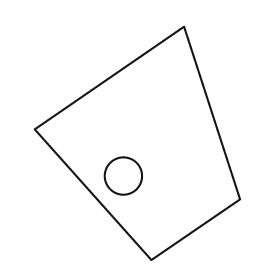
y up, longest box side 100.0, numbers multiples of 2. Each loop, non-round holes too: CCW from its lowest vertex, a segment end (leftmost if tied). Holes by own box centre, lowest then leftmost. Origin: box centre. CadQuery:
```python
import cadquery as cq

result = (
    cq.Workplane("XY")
    .moveTo(6.0, -50.0)
    .lineTo(44.0, -24.0)
    .lineTo(20.0, 50.0)
    .lineTo(-44.0, 6.0)
    .close()
    .moveTo(-6.0, -14.0)
    .circle(8.0)
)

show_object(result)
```